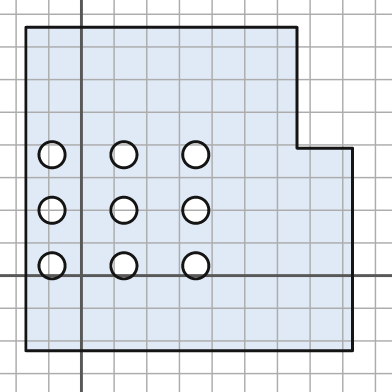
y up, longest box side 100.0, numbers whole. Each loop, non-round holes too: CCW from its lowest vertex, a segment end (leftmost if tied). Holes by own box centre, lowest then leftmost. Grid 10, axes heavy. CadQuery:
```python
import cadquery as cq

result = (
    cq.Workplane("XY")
    .moveTo(-17.0, -23.0)
    .lineTo(83.0, -23.0)
    .lineTo(83.0, 39.0)
    .lineTo(66.0, 39.0)
    .lineTo(66.0, 76.0)
    .lineTo(-17.0, 76.0)
    .close()
    .moveTo(-9.0, 3.0)
    .circle(4.0)
    .moveTo(13.0, 3.0)
    .circle(4.0)
    .moveTo(35.0, 3.0)
    .circle(4.0)
    .moveTo(-9.0, 20.0)
    .circle(4.0)
    .moveTo(13.0, 20.0)
    .circle(4.0)
    .moveTo(35.0, 20.0)
    .circle(4.0)
    .moveTo(-9.0, 37.0)
    .circle(4.0)
    .moveTo(13.0, 37.0)
    .circle(4.0)
    .moveTo(35.0, 37.0)
    .circle(4.0)
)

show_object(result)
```